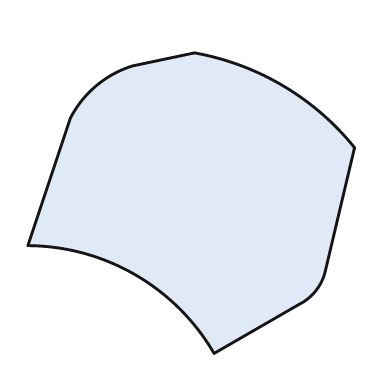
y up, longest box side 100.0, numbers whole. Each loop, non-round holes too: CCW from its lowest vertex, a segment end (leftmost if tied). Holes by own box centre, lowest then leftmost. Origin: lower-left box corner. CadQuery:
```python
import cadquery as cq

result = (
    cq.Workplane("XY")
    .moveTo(57.0, 0.0)
    .lineTo(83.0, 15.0)
    .threePointArc((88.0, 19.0), (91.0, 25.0))
    .lineTo(100.0, 63.0)
    .threePointArc((78.0, 82.0), (51.0, 92.0))
    .lineTo(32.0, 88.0)
    .threePointArc((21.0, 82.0), (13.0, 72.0))
    .lineTo(0.0, 33.0)
    .threePointArc((33.0, 24.0), (57.0, 0.0))
    .close()
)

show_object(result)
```